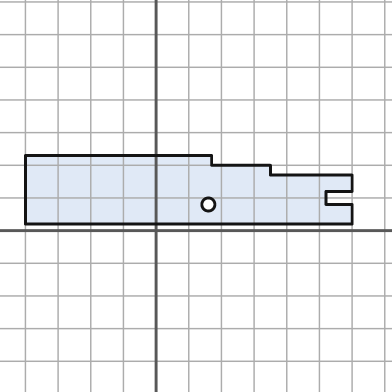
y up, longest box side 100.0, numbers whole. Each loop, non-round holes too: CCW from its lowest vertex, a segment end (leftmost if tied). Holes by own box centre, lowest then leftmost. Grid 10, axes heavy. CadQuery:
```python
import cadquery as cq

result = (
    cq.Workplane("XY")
    .moveTo(-40.0, 2.0)
    .lineTo(60.0, 2.0)
    .lineTo(60.0, 8.0)
    .lineTo(52.0, 8.0)
    .lineTo(52.0, 12.0)
    .lineTo(60.0, 12.0)
    .lineTo(60.0, 17.0)
    .lineTo(35.0, 17.0)
    .lineTo(35.0, 20.0)
    .lineTo(17.0, 20.0)
    .lineTo(17.0, 23.0)
    .lineTo(-40.0, 23.0)
    .close()
    .moveTo(16.0, 8.0)
    .circle(2.0)
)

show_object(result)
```